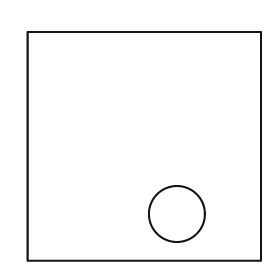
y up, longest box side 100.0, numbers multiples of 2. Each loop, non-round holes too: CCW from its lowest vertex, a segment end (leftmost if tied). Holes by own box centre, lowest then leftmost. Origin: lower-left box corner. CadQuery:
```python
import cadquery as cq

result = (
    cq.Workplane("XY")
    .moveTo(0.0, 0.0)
    .lineTo(100.0, 0.0)
    .lineTo(100.0, 98.0)
    .lineTo(0.0, 98.0)
    .close()
    .moveTo(64.0, 20.0)
    .circle(12.0)
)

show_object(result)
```